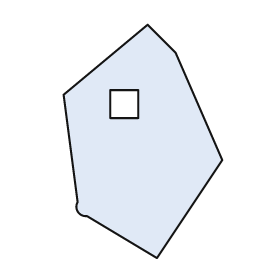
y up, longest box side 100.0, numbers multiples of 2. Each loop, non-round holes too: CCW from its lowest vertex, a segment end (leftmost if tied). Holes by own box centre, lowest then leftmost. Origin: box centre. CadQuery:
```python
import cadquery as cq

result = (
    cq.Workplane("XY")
    .moveTo(6.0, -50.0)
    .lineTo(34.0, -8.0)
    .lineTo(14.0, 38.0)
    .lineTo(2.0, 50.0)
    .lineTo(-34.0, 20.0)
    .lineTo(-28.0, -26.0)
    .threePointArc((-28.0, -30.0), (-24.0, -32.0))
    .close()
    .moveTo(-14.0, 10.0)
    .lineTo(-2.0, 10.0)
    .lineTo(-2.0, 22.0)
    .lineTo(-14.0, 22.0)
    .close()
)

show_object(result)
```